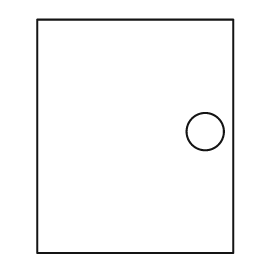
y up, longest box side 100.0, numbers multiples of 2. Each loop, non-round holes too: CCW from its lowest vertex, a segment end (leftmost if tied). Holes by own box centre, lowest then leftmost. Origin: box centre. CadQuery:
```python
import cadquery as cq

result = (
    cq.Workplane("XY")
    .moveTo(-42.0, -50.0)
    .lineTo(42.0, -50.0)
    .lineTo(42.0, 50.0)
    .lineTo(-42.0, 50.0)
    .close()
    .moveTo(30.0, 2.0)
    .circle(8.0)
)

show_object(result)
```